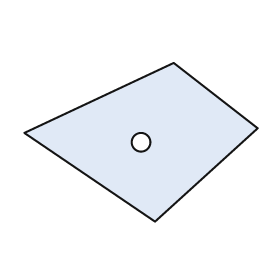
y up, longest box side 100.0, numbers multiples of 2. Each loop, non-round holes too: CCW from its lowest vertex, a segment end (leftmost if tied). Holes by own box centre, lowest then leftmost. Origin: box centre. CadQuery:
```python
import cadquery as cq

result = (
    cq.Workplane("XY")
    .moveTo(6.0, -34.0)
    .lineTo(50.0, 6.0)
    .lineTo(14.0, 34.0)
    .lineTo(-50.0, 4.0)
    .close()
    .moveTo(0.0, 0.0)
    .circle(4.0)
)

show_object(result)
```